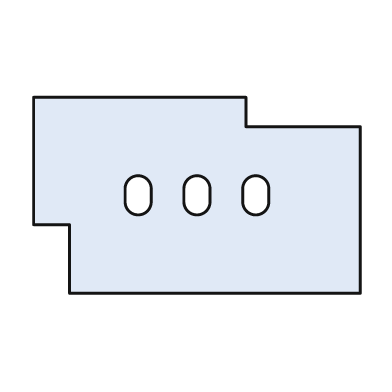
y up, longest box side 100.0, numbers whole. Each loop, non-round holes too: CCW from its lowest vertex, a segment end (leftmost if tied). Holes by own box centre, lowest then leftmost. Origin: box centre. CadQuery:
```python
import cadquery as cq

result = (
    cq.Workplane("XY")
    .moveTo(-39.0, -30.0)
    .lineTo(50.0, -30.0)
    .lineTo(50.0, 21.0)
    .lineTo(15.0, 21.0)
    .lineTo(15.0, 30.0)
    .lineTo(-50.0, 30.0)
    .lineTo(-50.0, -9.0)
    .lineTo(-39.0, -9.0)
    .close()
    .moveTo(-22.0, -2.0)
    .threePointArc((-18.0, -6.0), (-14.0, -2.0))
    .lineTo(-14.0, 2.0)
    .threePointArc((-18.0, 6.0), (-22.0, 2.0))
    .close()
    .moveTo(-4.0, -2.0)
    .threePointArc((0.0, -6.0), (4.0, -2.0))
    .lineTo(4.0, 2.0)
    .threePointArc((0.0, 6.0), (-4.0, 2.0))
    .close()
    .moveTo(14.0, -2.0)
    .threePointArc((18.0, -6.0), (22.0, -2.0))
    .lineTo(22.0, 2.0)
    .threePointArc((18.0, 6.0), (14.0, 2.0))
    .close()
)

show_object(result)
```